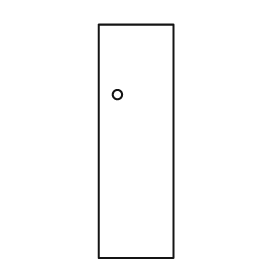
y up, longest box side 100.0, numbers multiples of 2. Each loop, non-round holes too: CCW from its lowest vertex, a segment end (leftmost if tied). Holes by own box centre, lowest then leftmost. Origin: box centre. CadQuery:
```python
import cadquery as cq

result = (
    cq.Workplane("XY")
    .moveTo(-16.0, -50.0)
    .lineTo(16.0, -50.0)
    .lineTo(16.0, 50.0)
    .lineTo(-16.0, 50.0)
    .close()
    .moveTo(-8.0, 20.0)
    .circle(2.0)
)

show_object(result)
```